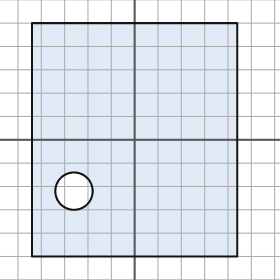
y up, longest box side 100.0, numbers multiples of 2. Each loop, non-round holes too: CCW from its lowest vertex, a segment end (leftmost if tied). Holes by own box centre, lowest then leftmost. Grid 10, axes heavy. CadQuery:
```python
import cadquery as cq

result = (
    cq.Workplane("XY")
    .moveTo(-44.0, -50.0)
    .lineTo(44.0, -50.0)
    .lineTo(44.0, 50.0)
    .lineTo(-44.0, 50.0)
    .close()
    .moveTo(-26.0, -22.0)
    .circle(8.0)
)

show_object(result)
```